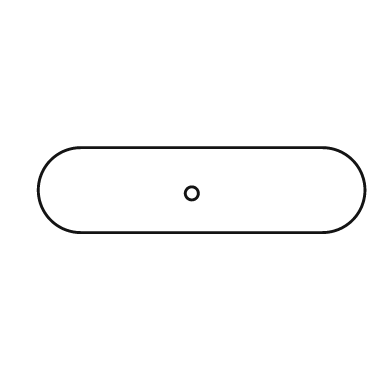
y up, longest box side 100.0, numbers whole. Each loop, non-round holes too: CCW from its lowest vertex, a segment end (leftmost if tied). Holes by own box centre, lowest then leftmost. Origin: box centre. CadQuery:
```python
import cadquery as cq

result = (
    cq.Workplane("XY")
    .moveTo(-37.0, -13.0)
    .lineTo(37.0, -13.0)
    .threePointArc((50.0, 0.0), (37.0, 13.0))
    .lineTo(-37.0, 13.0)
    .threePointArc((-50.0, 0.0), (-37.0, -13.0))
    .close()
    .moveTo(-3.0, -1.0)
    .circle(2.0)
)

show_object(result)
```